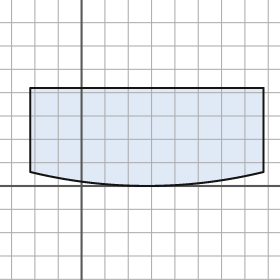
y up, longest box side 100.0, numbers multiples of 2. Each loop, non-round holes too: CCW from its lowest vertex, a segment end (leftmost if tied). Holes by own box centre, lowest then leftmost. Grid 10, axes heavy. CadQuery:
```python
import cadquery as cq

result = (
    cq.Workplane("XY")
    .moveTo(-22.0, 6.0)
    .threePointArc((28.0, 0.0), (78.0, 6.0))
    .lineTo(78.0, 42.0)
    .lineTo(-22.0, 42.0)
    .close()
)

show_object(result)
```